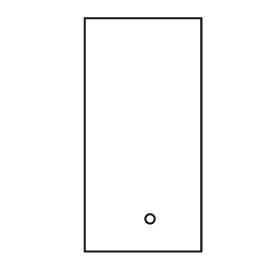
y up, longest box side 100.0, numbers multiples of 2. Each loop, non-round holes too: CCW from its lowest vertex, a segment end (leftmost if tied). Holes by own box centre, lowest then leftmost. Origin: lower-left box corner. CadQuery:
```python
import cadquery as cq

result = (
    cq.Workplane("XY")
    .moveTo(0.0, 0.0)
    .lineTo(50.0, 0.0)
    .lineTo(50.0, 100.0)
    .lineTo(0.0, 100.0)
    .close()
    .moveTo(28.0, 14.0)
    .circle(2.0)
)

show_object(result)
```